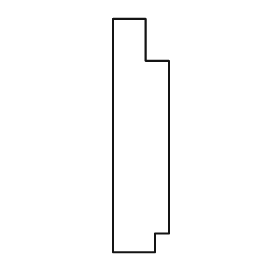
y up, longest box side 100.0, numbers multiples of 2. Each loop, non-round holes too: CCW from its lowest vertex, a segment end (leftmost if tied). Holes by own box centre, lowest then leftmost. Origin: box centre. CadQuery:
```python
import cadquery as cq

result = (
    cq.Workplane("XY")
    .moveTo(-12.0, -50.0)
    .lineTo(6.0, -50.0)
    .lineTo(6.0, -42.0)
    .lineTo(12.0, -42.0)
    .lineTo(12.0, 32.0)
    .lineTo(2.0, 32.0)
    .lineTo(2.0, 50.0)
    .lineTo(-12.0, 50.0)
    .close()
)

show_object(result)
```